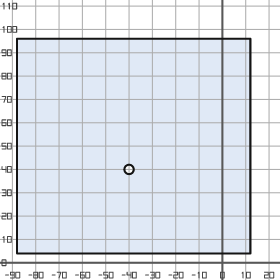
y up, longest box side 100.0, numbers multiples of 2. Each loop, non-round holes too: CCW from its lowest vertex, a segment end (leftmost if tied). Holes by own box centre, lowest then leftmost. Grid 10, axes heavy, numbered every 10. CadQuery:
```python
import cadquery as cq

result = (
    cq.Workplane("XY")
    .moveTo(-88.0, 4.0)
    .lineTo(12.0, 4.0)
    .lineTo(12.0, 96.0)
    .lineTo(-88.0, 96.0)
    .close()
    .moveTo(-40.0, 40.0)
    .circle(2.0)
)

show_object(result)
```